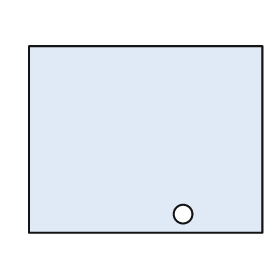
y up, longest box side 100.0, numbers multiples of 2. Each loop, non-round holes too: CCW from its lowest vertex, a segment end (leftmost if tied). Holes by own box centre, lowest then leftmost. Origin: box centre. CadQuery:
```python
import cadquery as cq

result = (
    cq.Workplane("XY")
    .moveTo(-50.0, -40.0)
    .lineTo(50.0, -40.0)
    .lineTo(50.0, 40.0)
    .lineTo(-50.0, 40.0)
    .close()
    .moveTo(16.0, -32.0)
    .circle(4.0)
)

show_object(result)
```